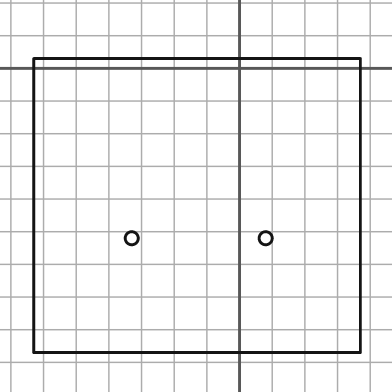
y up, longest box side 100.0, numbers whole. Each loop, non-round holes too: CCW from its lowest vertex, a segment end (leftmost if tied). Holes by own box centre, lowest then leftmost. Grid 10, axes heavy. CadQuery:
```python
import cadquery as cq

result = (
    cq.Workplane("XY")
    .moveTo(-63.0, -87.0)
    .lineTo(37.0, -87.0)
    .lineTo(37.0, 3.0)
    .lineTo(-63.0, 3.0)
    .close()
    .moveTo(-33.0, -52.0)
    .circle(2.0)
    .moveTo(8.0, -52.0)
    .circle(2.0)
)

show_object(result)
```